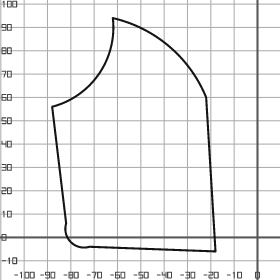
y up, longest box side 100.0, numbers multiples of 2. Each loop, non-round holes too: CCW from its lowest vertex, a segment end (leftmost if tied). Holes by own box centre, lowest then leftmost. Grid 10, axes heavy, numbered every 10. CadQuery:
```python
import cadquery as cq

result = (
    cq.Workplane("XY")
    .moveTo(-18.0, -6.0)
    .lineTo(-22.0, 60.0)
    .threePointArc((-38.0, 82.0), (-62.0, 94.0))
    .threePointArc((-68.0, 70.0), (-88.0, 56.0))
    .lineTo(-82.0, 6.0)
    .threePointArc((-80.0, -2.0), (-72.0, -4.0))
    .close()
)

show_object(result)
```